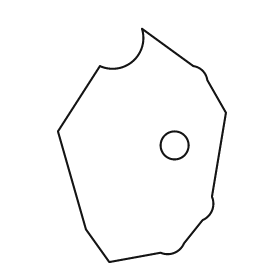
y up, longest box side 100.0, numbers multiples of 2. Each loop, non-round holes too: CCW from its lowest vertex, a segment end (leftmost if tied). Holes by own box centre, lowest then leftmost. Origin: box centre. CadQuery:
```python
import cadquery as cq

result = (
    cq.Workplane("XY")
    .moveTo(-14.0, -50.0)
    .lineTo(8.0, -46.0)
    .threePointArc((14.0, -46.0), (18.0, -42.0))
    .lineTo(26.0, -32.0)
    .threePointArc((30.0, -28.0), (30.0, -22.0))
    .lineTo(36.0, 14.0)
    .lineTo(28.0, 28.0)
    .threePointArc((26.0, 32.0), (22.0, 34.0))
    .lineTo(0.0, 50.0)
    .threePointArc((-4.0, 36.0), (-18.0, 34.0))
    .lineTo(-36.0, 6.0)
    .lineTo(-24.0, -36.0)
    .close()
    .moveTo(14.0, 0.0)
    .circle(6.0)
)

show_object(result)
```